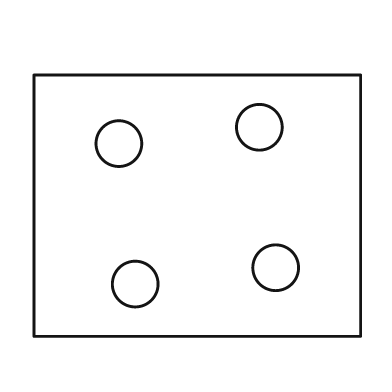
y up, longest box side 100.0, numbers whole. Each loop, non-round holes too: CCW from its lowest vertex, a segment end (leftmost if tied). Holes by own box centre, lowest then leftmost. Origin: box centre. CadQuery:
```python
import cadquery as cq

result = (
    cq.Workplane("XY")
    .moveTo(-50.0, -40.0)
    .lineTo(50.0, -40.0)
    .lineTo(50.0, 40.0)
    .lineTo(-50.0, 40.0)
    .close()
    .moveTo(-19.0, -24.0)
    .circle(7.0)
    .moveTo(24.0, -19.0)
    .circle(7.0)
    .moveTo(-24.0, 19.0)
    .circle(7.0)
    .moveTo(19.0, 24.0)
    .circle(7.0)
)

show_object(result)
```